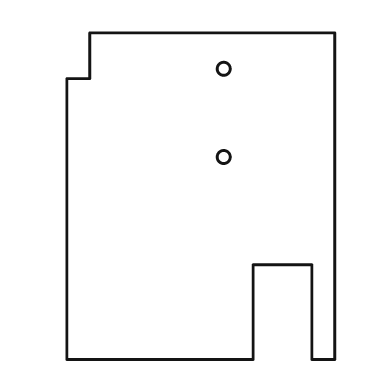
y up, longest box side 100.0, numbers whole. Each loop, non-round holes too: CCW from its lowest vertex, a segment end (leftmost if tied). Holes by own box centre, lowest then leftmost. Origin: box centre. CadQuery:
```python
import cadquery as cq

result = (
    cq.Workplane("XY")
    .moveTo(-41.0, -50.0)
    .lineTo(16.0, -50.0)
    .lineTo(16.0, -21.0)
    .lineTo(34.0, -21.0)
    .lineTo(34.0, -50.0)
    .lineTo(41.0, -50.0)
    .lineTo(41.0, 50.0)
    .lineTo(-34.0, 50.0)
    .lineTo(-34.0, 36.0)
    .lineTo(-41.0, 36.0)
    .close()
    .moveTo(7.0, 12.0)
    .circle(2.0)
    .moveTo(7.0, 39.0)
    .circle(2.0)
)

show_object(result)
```